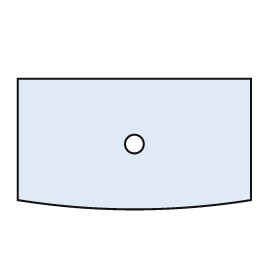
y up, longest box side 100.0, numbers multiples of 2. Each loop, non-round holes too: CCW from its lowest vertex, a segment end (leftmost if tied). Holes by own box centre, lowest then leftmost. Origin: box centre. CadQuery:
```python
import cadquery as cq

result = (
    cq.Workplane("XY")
    .moveTo(-50.0, -24.0)
    .threePointArc((0.0, -28.0), (50.0, -24.0))
    .lineTo(50.0, 28.0)
    .lineTo(-50.0, 28.0)
    .close()
    .moveTo(0.0, 0.0)
    .circle(4.0)
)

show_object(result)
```